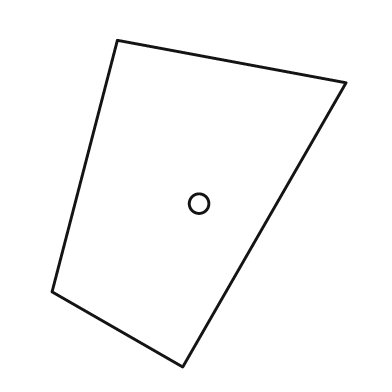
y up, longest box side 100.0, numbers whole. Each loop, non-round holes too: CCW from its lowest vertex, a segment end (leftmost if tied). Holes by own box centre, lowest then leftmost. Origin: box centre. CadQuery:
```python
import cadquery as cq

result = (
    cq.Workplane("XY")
    .moveTo(-5.0, -50.0)
    .lineTo(45.0, 37.0)
    .lineTo(-25.0, 50.0)
    .lineTo(-45.0, -27.0)
    .close()
    .moveTo(0.0, 0.0)
    .circle(3.0)
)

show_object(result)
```